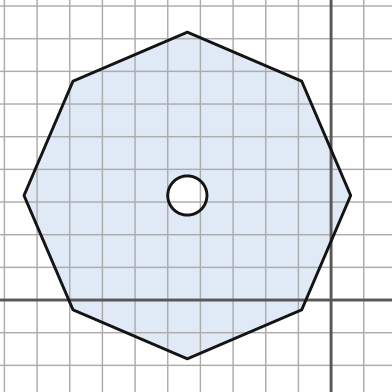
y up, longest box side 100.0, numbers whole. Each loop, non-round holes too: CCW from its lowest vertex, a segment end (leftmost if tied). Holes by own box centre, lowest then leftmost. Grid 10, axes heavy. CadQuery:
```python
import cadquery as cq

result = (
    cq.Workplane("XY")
    .moveTo(-44.0, -18.0)
    .lineTo(-9.0, -3.0)
    .lineTo(6.0, 32.0)
    .lineTo(-9.0, 67.0)
    .lineTo(-44.0, 82.0)
    .lineTo(-79.0, 67.0)
    .lineTo(-94.0, 32.0)
    .lineTo(-79.0, -3.0)
    .close()
    .moveTo(-44.0, 32.0)
    .circle(6.0)
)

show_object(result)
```